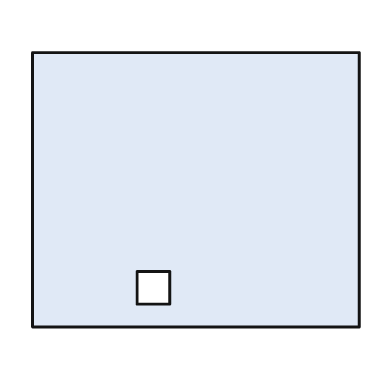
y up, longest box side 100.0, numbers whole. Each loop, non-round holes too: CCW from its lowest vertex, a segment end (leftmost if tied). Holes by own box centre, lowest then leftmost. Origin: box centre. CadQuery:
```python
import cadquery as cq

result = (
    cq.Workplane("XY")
    .moveTo(-50.0, -42.0)
    .lineTo(50.0, -42.0)
    .lineTo(50.0, 42.0)
    .lineTo(-50.0, 42.0)
    .close()
    .moveTo(-18.0, -35.0)
    .lineTo(-8.0, -35.0)
    .lineTo(-8.0, -25.0)
    .lineTo(-18.0, -25.0)
    .close()
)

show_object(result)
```